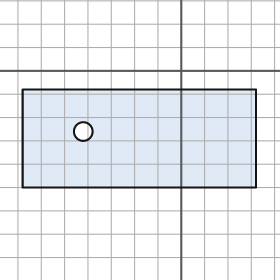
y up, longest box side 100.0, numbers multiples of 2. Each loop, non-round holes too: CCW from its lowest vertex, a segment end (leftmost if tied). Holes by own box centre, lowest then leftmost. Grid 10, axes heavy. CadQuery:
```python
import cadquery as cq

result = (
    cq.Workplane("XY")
    .moveTo(-68.0, -50.0)
    .lineTo(32.0, -50.0)
    .lineTo(32.0, -8.0)
    .lineTo(-68.0, -8.0)
    .close()
    .moveTo(-42.0, -26.0)
    .circle(4.0)
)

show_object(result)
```